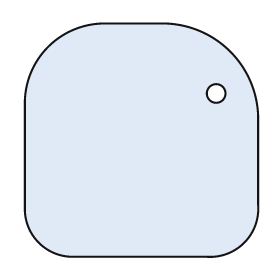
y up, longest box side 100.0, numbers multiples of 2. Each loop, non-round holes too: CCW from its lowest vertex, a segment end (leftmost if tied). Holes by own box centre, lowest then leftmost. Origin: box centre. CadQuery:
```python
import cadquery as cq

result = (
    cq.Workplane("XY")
    .moveTo(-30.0, -50.0)
    .lineTo(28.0, -50.0)
    .threePointArc((44.0, -44.0), (50.0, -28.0))
    .lineTo(50.0, 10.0)
    .threePointArc((38.0, 38.0), (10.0, 50.0))
    .lineTo(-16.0, 50.0)
    .threePointArc((-40.0, 40.0), (-50.0, 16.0))
    .lineTo(-50.0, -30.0)
    .threePointArc((-44.0, -44.0), (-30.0, -50.0))
    .close()
    .moveTo(32.0, 20.0)
    .circle(4.0)
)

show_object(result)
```